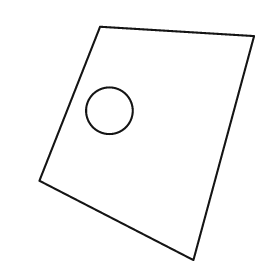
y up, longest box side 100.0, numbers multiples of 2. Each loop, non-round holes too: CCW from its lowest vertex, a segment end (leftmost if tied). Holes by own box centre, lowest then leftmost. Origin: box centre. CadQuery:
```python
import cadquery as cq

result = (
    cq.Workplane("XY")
    .moveTo(20.0, -50.0)
    .lineTo(46.0, 46.0)
    .lineTo(-20.0, 50.0)
    .lineTo(-46.0, -16.0)
    .close()
    .moveTo(-16.0, 14.0)
    .circle(10.0)
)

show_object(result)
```